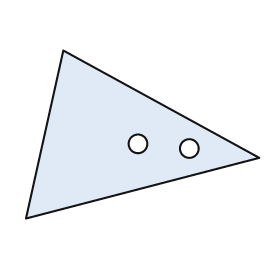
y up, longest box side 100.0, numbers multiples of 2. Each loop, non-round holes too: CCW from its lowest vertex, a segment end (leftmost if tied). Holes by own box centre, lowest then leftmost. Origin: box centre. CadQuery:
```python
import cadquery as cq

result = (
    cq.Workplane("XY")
    .moveTo(-50.0, -36.0)
    .lineTo(50.0, -10.0)
    .lineTo(-34.0, 36.0)
    .close()
    .moveTo(20.0, -6.0)
    .circle(4.0)
    .moveTo(-2.0, -4.0)
    .circle(4.0)
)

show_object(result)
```